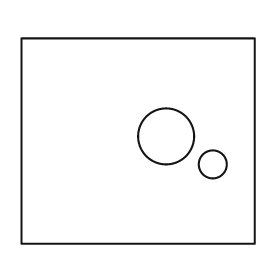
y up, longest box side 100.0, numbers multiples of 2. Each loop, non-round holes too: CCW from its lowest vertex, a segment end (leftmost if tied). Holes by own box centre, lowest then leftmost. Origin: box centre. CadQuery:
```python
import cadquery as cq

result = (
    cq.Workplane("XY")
    .moveTo(-50.0, -44.0)
    .lineTo(50.0, -44.0)
    .lineTo(50.0, 44.0)
    .lineTo(-50.0, 44.0)
    .close()
    .moveTo(32.0, -10.0)
    .circle(6.0)
    .moveTo(12.0, 2.0)
    .circle(12.0)
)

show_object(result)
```